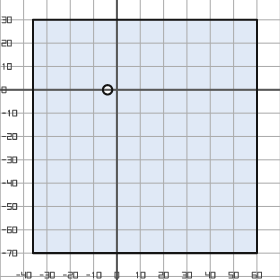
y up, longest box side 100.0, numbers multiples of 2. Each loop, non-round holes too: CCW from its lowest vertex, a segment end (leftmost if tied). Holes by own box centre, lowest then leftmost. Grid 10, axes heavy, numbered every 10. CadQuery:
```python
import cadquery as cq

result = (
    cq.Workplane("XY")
    .moveTo(-36.0, -70.0)
    .lineTo(60.0, -70.0)
    .lineTo(60.0, 30.0)
    .lineTo(-36.0, 30.0)
    .close()
    .moveTo(-4.0, 0.0)
    .circle(2.0)
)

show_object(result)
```